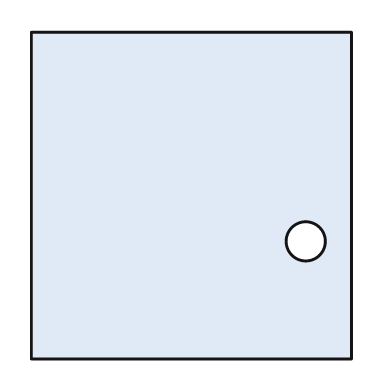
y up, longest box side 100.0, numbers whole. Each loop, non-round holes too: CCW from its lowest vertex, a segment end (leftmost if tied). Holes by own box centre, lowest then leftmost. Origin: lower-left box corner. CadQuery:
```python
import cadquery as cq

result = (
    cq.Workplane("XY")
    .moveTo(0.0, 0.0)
    .lineTo(98.0, 0.0)
    .lineTo(98.0, 100.0)
    .lineTo(0.0, 100.0)
    .close()
    .moveTo(84.0, 36.0)
    .circle(6.0)
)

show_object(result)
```